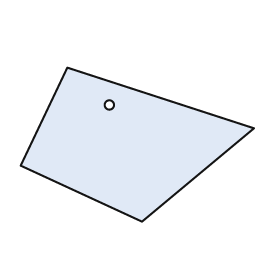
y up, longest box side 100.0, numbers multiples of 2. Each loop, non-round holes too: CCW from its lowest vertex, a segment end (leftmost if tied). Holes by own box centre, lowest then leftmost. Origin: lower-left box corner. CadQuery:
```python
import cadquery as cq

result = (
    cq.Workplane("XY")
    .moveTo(52.0, 0.0)
    .lineTo(100.0, 40.0)
    .lineTo(20.0, 66.0)
    .lineTo(0.0, 24.0)
    .close()
    .moveTo(38.0, 50.0)
    .circle(2.0)
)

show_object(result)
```